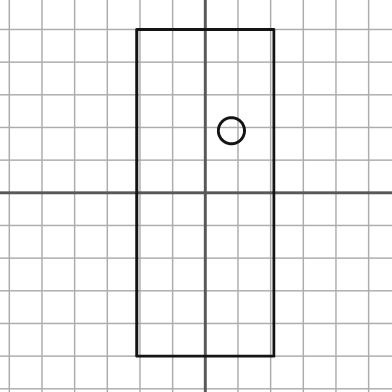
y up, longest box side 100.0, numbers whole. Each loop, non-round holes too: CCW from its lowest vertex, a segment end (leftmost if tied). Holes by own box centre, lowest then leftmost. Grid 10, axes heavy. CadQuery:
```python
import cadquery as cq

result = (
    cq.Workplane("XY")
    .moveTo(-21.0, -50.0)
    .lineTo(21.0, -50.0)
    .lineTo(21.0, 50.0)
    .lineTo(-21.0, 50.0)
    .close()
    .moveTo(8.0, 19.0)
    .circle(4.0)
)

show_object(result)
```